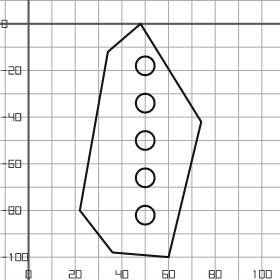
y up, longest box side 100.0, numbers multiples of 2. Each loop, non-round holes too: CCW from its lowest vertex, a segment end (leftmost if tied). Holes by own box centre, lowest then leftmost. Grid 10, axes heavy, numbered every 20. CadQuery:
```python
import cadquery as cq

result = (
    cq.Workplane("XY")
    .moveTo(60.0, -100.0)
    .lineTo(74.0, -42.0)
    .lineTo(48.0, 0.0)
    .lineTo(34.0, -12.0)
    .lineTo(22.0, -80.0)
    .lineTo(36.0, -98.0)
    .close()
    .moveTo(50.0, -82.0)
    .circle(4.0)
    .moveTo(50.0, -66.0)
    .circle(4.0)
    .moveTo(50.0, -50.0)
    .circle(4.0)
    .moveTo(50.0, -34.0)
    .circle(4.0)
    .moveTo(50.0, -18.0)
    .circle(4.0)
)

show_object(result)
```